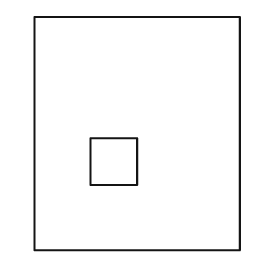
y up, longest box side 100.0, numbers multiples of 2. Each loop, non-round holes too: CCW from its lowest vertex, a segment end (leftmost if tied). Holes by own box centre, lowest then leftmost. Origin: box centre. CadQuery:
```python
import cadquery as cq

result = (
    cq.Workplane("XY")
    .moveTo(-44.0, -50.0)
    .lineTo(44.0, -50.0)
    .lineTo(44.0, 50.0)
    .lineTo(-44.0, 50.0)
    .close()
    .moveTo(-20.0, -22.0)
    .lineTo(0.0, -22.0)
    .lineTo(0.0, -2.0)
    .lineTo(-20.0, -2.0)
    .close()
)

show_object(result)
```